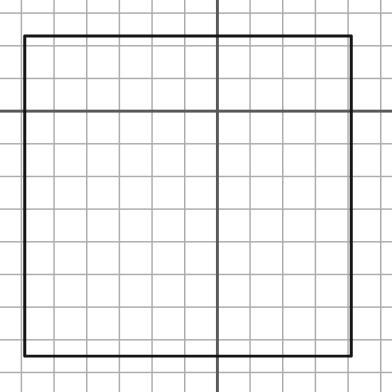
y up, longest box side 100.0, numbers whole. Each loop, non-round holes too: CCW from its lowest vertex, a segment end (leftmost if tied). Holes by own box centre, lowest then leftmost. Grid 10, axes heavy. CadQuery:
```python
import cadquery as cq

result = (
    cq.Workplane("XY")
    .moveTo(-59.0, -75.0)
    .lineTo(41.0, -75.0)
    .lineTo(41.0, 23.0)
    .lineTo(-59.0, 23.0)
    .close()
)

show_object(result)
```